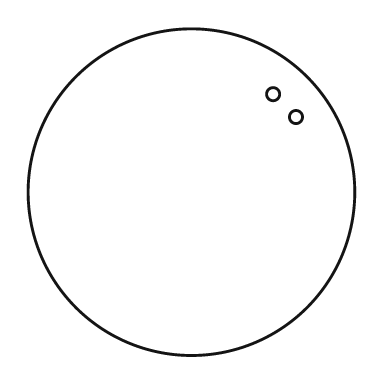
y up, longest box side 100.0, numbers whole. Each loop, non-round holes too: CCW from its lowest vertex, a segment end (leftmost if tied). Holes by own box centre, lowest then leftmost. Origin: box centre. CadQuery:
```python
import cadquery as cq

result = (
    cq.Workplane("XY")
    .moveTo(0.0, 0.0)
    .circle(50.0)
    .moveTo(32.0, 23.0)
    .circle(2.0)
    .moveTo(25.0, 30.0)
    .circle(2.0)
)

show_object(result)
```